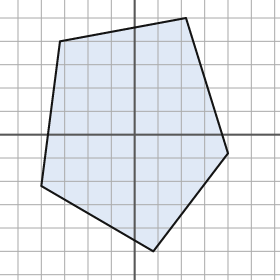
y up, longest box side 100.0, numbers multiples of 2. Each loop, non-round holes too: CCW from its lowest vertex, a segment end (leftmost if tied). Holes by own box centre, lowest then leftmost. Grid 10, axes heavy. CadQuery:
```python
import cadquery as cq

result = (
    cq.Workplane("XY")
    .moveTo(8.0, -50.0)
    .lineTo(40.0, -8.0)
    .lineTo(22.0, 50.0)
    .lineTo(-32.0, 40.0)
    .lineTo(-40.0, -22.0)
    .close()
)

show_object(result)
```